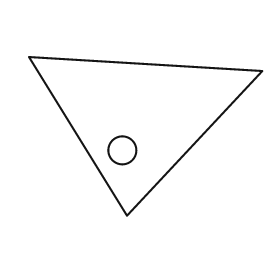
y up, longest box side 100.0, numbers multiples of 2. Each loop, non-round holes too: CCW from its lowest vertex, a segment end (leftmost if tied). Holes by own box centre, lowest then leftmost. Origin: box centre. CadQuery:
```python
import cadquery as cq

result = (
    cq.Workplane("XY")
    .moveTo(-8.0, -34.0)
    .lineTo(50.0, 28.0)
    .lineTo(-50.0, 34.0)
    .close()
    .moveTo(-10.0, -6.0)
    .circle(6.0)
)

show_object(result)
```